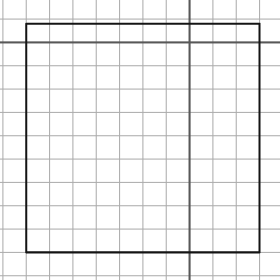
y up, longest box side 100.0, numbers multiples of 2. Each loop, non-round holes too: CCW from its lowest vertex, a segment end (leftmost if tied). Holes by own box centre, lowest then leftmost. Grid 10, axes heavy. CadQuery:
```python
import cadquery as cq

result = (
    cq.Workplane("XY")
    .moveTo(-70.0, -90.0)
    .lineTo(30.0, -90.0)
    .lineTo(30.0, 8.0)
    .lineTo(-70.0, 8.0)
    .close()
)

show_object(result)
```